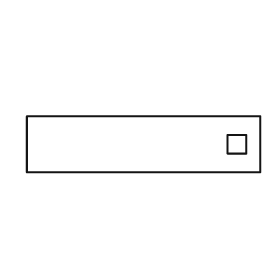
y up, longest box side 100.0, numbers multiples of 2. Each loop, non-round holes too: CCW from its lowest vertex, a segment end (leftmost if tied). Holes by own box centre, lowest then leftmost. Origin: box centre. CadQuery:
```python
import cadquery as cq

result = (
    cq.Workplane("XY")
    .moveTo(-50.0, -12.0)
    .lineTo(50.0, -12.0)
    .lineTo(50.0, 12.0)
    .lineTo(-50.0, 12.0)
    .close()
    .moveTo(36.0, -4.0)
    .lineTo(44.0, -4.0)
    .lineTo(44.0, 4.0)
    .lineTo(36.0, 4.0)
    .close()
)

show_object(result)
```